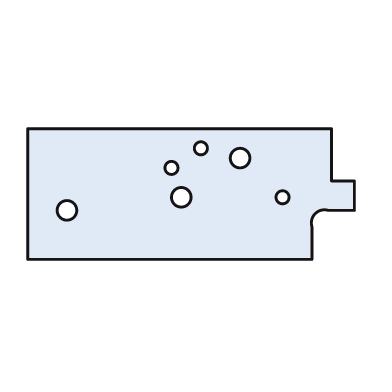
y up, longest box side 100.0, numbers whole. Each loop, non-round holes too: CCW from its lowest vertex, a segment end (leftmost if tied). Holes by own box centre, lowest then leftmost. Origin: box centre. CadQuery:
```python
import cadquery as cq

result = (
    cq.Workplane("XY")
    .moveTo(-50.0, -20.0)
    .lineTo(37.0, -20.0)
    .lineTo(37.0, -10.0)
    .threePointArc((38.0, -6.0), (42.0, -5.0))
    .lineTo(50.0, -5.0)
    .lineTo(50.0, 4.0)
    .lineTo(43.0, 4.0)
    .lineTo(43.0, 20.0)
    .lineTo(-50.0, 20.0)
    .close()
    .moveTo(-38.0, -5.0)
    .circle(3.0)
    .moveTo(-3.0, -1.0)
    .circle(3.0)
    .moveTo(28.0, -1.0)
    .circle(2.0)
    .moveTo(-6.0, 8.0)
    .circle(2.0)
    .moveTo(15.0, 11.0)
    .circle(3.0)
    .moveTo(3.0, 14.0)
    .circle(2.0)
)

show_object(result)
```